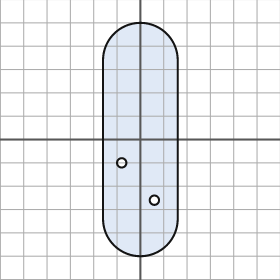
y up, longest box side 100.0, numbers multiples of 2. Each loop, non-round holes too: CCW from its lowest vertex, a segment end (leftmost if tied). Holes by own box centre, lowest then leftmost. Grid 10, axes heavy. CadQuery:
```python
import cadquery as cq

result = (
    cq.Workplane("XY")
    .moveTo(-16.0, -34.0)
    .threePointArc((0.0, -50.0), (16.0, -34.0))
    .lineTo(16.0, 34.0)
    .threePointArc((0.0, 50.0), (-16.0, 34.0))
    .close()
    .moveTo(6.0, -26.0)
    .circle(2.0)
    .moveTo(-8.0, -10.0)
    .circle(2.0)
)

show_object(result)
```